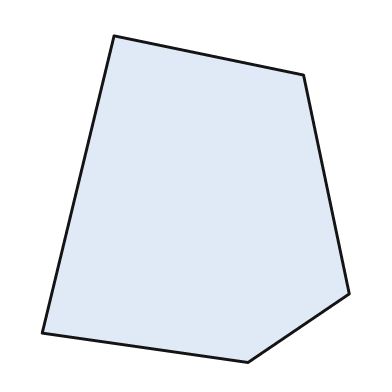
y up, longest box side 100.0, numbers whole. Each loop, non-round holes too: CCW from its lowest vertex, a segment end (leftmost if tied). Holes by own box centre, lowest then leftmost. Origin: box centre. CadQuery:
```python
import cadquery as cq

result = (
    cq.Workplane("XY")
    .moveTo(16.0, -50.0)
    .lineTo(47.0, -29.0)
    .lineTo(33.0, 38.0)
    .lineTo(-25.0, 50.0)
    .lineTo(-47.0, -41.0)
    .close()
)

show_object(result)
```